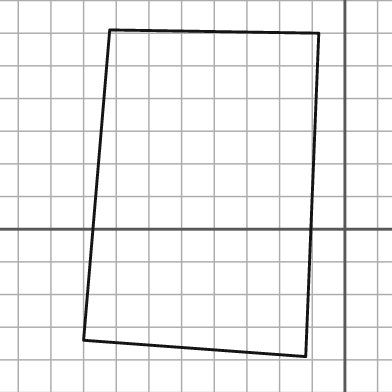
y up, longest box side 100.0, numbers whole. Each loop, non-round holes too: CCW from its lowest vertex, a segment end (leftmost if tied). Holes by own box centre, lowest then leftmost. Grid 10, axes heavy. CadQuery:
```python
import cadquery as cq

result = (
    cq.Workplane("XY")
    .moveTo(-12.0, -39.0)
    .lineTo(-8.0, 60.0)
    .lineTo(-72.0, 61.0)
    .lineTo(-80.0, -34.0)
    .close()
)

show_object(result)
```